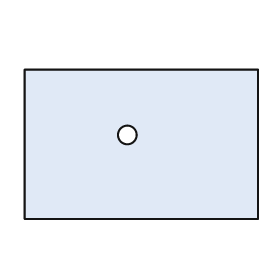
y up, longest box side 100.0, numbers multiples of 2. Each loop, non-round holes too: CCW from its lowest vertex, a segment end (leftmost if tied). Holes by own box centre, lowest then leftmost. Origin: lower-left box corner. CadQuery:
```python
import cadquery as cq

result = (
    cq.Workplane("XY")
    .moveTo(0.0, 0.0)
    .lineTo(100.0, 0.0)
    .lineTo(100.0, 64.0)
    .lineTo(0.0, 64.0)
    .close()
    .moveTo(44.0, 36.0)
    .circle(4.0)
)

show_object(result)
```